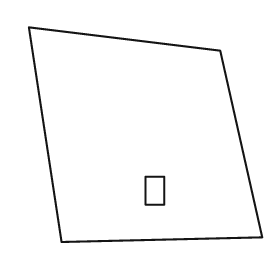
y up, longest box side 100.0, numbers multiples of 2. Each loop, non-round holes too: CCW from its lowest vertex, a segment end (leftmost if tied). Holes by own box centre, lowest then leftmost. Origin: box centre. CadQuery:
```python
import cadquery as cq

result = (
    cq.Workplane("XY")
    .moveTo(-36.0, -46.0)
    .lineTo(50.0, -44.0)
    .lineTo(32.0, 36.0)
    .lineTo(-50.0, 46.0)
    .close()
    .moveTo(0.0, -30.0)
    .lineTo(8.0, -30.0)
    .lineTo(8.0, -18.0)
    .lineTo(0.0, -18.0)
    .close()
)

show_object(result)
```